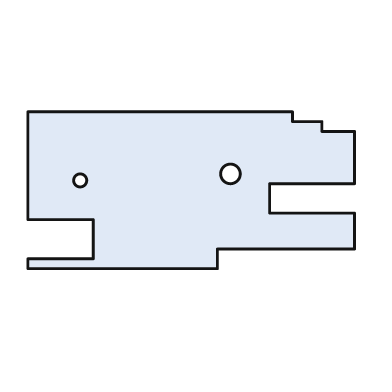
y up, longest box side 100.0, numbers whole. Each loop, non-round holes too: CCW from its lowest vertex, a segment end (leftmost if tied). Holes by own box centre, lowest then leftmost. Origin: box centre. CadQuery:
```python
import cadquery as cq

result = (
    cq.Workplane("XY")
    .moveTo(-50.0, -24.0)
    .lineTo(8.0, -24.0)
    .lineTo(8.0, -18.0)
    .lineTo(50.0, -18.0)
    .lineTo(50.0, -7.0)
    .lineTo(24.0, -7.0)
    .lineTo(24.0, 2.0)
    .lineTo(50.0, 2.0)
    .lineTo(50.0, 18.0)
    .lineTo(40.0, 18.0)
    .lineTo(40.0, 21.0)
    .lineTo(31.0, 21.0)
    .lineTo(31.0, 24.0)
    .lineTo(-50.0, 24.0)
    .lineTo(-50.0, -9.0)
    .lineTo(-30.0, -9.0)
    .lineTo(-30.0, -21.0)
    .lineTo(-50.0, -21.0)
    .close()
    .moveTo(-34.0, 3.0)
    .circle(2.0)
    .moveTo(12.0, 5.0)
    .circle(3.0)
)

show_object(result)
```